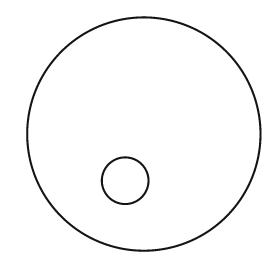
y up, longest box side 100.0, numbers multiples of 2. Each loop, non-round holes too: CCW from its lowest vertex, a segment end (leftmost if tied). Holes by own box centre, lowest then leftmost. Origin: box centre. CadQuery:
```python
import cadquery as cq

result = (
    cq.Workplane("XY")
    .moveTo(0.0, 0.0)
    .circle(50.0)
    .moveTo(-8.0, -20.0)
    .circle(10.0)
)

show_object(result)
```